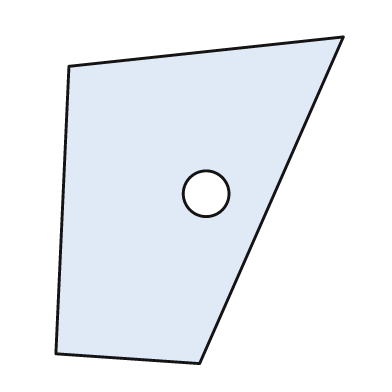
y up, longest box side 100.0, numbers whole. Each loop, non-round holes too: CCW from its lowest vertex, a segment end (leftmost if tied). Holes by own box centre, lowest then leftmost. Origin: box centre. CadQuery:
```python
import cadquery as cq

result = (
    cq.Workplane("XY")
    .moveTo(0.0, -50.0)
    .lineTo(44.0, 50.0)
    .lineTo(-40.0, 41.0)
    .lineTo(-44.0, -47.0)
    .close()
    .moveTo(2.0, 2.0)
    .circle(7.0)
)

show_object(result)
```